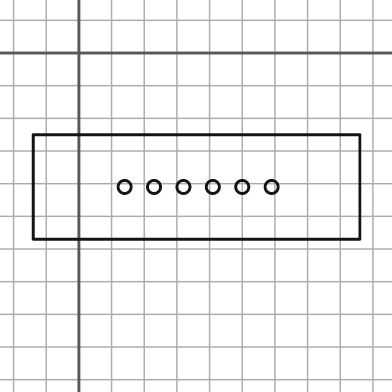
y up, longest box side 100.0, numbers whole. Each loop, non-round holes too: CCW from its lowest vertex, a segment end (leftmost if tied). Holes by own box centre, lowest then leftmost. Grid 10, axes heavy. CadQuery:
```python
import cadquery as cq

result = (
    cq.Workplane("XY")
    .moveTo(-14.0, -57.0)
    .lineTo(86.0, -57.0)
    .lineTo(86.0, -25.0)
    .lineTo(-14.0, -25.0)
    .close()
    .moveTo(14.0, -41.0)
    .circle(2.0)
    .moveTo(23.0, -41.0)
    .circle(2.0)
    .moveTo(32.0, -41.0)
    .circle(2.0)
    .moveTo(41.0, -41.0)
    .circle(2.0)
    .moveTo(50.0, -41.0)
    .circle(2.0)
    .moveTo(59.0, -41.0)
    .circle(2.0)
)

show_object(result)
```